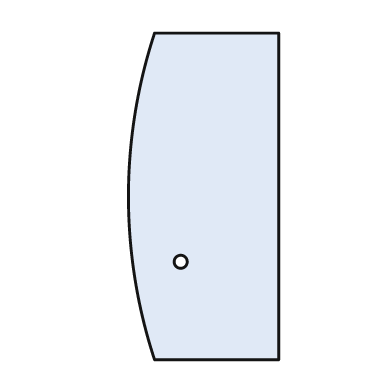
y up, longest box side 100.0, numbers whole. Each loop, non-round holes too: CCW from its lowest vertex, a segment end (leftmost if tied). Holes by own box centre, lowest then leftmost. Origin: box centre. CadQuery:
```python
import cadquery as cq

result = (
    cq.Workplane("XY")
    .moveTo(-15.0, -50.0)
    .lineTo(23.0, -50.0)
    .lineTo(23.0, 50.0)
    .lineTo(-15.0, 50.0)
    .threePointArc((-23.0, 0.0), (-15.0, -50.0))
    .close()
    .moveTo(-7.0, -20.0)
    .circle(2.0)
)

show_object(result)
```